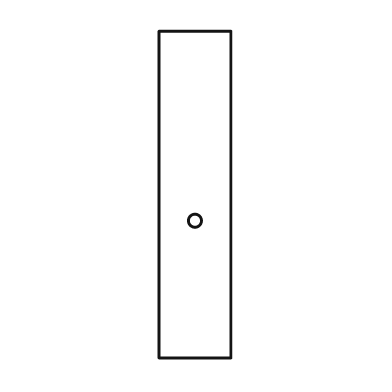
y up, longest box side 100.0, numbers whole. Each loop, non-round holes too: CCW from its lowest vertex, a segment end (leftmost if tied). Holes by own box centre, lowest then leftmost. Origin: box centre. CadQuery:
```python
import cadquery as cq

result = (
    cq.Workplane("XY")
    .moveTo(-11.0, -50.0)
    .lineTo(11.0, -50.0)
    .lineTo(11.0, 50.0)
    .lineTo(-11.0, 50.0)
    .close()
    .moveTo(0.0, -8.0)
    .circle(2.0)
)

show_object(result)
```